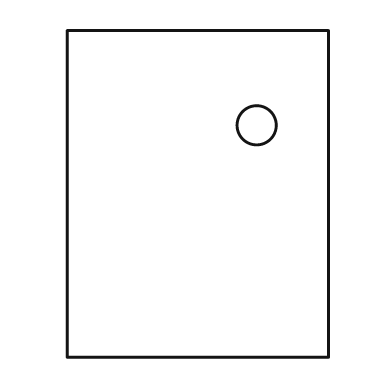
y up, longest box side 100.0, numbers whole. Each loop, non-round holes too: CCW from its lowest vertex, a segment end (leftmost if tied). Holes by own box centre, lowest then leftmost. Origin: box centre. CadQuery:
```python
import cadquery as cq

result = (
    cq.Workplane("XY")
    .moveTo(-40.0, -50.0)
    .lineTo(40.0, -50.0)
    .lineTo(40.0, 50.0)
    .lineTo(-40.0, 50.0)
    .close()
    .moveTo(18.0, 21.0)
    .circle(6.0)
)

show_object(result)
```